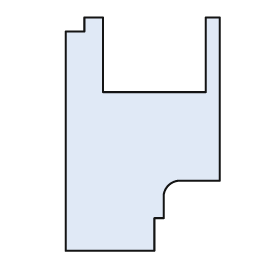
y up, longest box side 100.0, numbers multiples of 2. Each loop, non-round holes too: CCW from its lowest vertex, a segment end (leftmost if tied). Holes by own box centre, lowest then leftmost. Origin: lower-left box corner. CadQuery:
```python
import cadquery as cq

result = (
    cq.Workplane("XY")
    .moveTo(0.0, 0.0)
    .lineTo(38.0, 0.0)
    .lineTo(38.0, 14.0)
    .lineTo(42.0, 14.0)
    .lineTo(42.0, 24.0)
    .threePointArc((44.0, 28.0), (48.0, 30.0))
    .lineTo(66.0, 30.0)
    .lineTo(66.0, 100.0)
    .lineTo(60.0, 100.0)
    .lineTo(60.0, 68.0)
    .lineTo(16.0, 68.0)
    .lineTo(16.0, 100.0)
    .lineTo(8.0, 100.0)
    .lineTo(8.0, 94.0)
    .lineTo(0.0, 94.0)
    .close()
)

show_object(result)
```